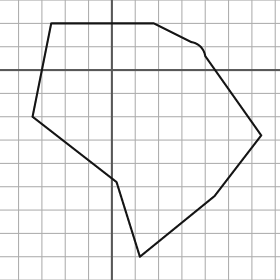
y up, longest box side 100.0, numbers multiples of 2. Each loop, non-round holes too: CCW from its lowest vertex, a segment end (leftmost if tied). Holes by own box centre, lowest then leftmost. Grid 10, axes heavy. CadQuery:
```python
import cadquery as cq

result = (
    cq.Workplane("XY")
    .moveTo(12.0, -80.0)
    .lineTo(44.0, -54.0)
    .lineTo(64.0, -28.0)
    .lineTo(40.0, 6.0)
    .threePointArc((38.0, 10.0), (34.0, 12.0))
    .lineTo(18.0, 20.0)
    .lineTo(-26.0, 20.0)
    .lineTo(-34.0, -20.0)
    .lineTo(2.0, -48.0)
    .close()
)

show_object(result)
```